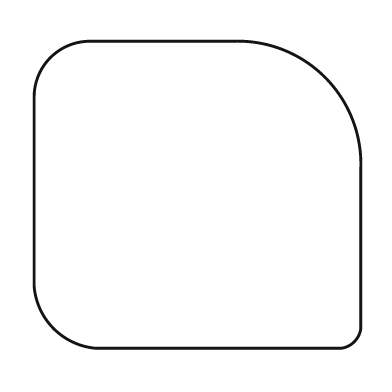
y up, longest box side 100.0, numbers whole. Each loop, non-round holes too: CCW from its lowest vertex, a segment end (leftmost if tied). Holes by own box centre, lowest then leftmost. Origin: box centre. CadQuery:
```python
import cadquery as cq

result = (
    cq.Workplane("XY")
    .moveTo(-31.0, -47.0)
    .lineTo(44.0, -47.0)
    .threePointArc((48.0, -45.0), (50.0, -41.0))
    .lineTo(50.0, 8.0)
    .threePointArc((39.0, 36.0), (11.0, 47.0))
    .lineTo(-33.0, 47.0)
    .threePointArc((-45.0, 42.0), (-50.0, 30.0))
    .lineTo(-50.0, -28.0)
    .threePointArc((-44.0, -41.0), (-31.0, -47.0))
    .close()
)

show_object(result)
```